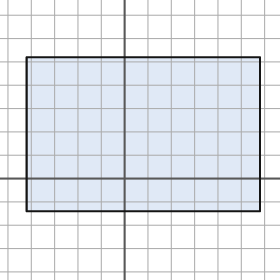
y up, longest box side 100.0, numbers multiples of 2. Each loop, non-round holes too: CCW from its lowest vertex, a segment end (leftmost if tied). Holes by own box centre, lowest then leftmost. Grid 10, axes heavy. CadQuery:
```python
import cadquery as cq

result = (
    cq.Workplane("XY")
    .moveTo(-42.0, -14.0)
    .lineTo(58.0, -14.0)
    .lineTo(58.0, 52.0)
    .lineTo(-42.0, 52.0)
    .close()
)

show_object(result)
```